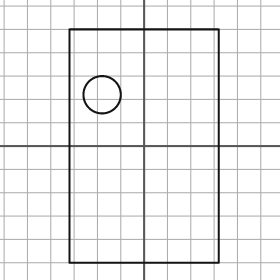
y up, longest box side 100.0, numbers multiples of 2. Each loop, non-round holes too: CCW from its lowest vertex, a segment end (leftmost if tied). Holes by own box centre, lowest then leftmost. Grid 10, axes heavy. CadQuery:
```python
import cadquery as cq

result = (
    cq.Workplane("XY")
    .moveTo(-32.0, -50.0)
    .lineTo(32.0, -50.0)
    .lineTo(32.0, 50.0)
    .lineTo(-32.0, 50.0)
    .close()
    .moveTo(-18.0, 22.0)
    .circle(8.0)
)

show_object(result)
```